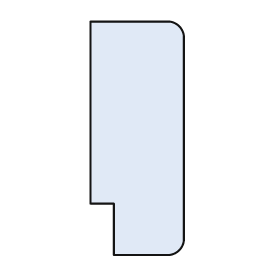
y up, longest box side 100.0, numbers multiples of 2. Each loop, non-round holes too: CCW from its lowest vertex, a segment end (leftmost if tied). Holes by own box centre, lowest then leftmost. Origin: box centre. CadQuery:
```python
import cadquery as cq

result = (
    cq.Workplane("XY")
    .moveTo(-10.0, -50.0)
    .lineTo(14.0, -50.0)
    .threePointArc((18.0, -48.0), (20.0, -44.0))
    .lineTo(20.0, 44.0)
    .threePointArc((18.0, 48.0), (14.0, 50.0))
    .lineTo(-20.0, 50.0)
    .lineTo(-20.0, -28.0)
    .lineTo(-10.0, -28.0)
    .close()
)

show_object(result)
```